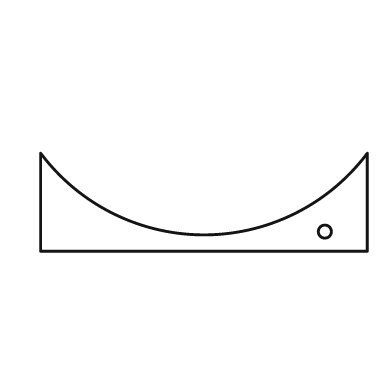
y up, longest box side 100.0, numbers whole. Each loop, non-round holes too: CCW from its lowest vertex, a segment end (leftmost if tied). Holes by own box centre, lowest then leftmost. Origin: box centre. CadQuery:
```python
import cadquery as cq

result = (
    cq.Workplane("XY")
    .moveTo(-50.0, -15.0)
    .lineTo(50.0, -15.0)
    .lineTo(50.0, 15.0)
    .threePointArc((0.0, -10.0), (-50.0, 15.0))
    .close()
    .moveTo(37.0, -9.0)
    .circle(2.0)
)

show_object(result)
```